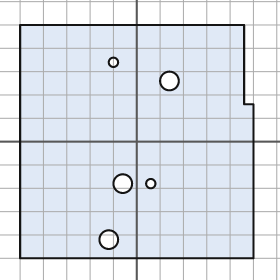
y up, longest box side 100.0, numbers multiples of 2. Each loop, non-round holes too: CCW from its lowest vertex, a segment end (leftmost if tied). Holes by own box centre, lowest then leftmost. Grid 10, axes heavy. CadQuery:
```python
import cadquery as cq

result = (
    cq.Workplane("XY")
    .moveTo(-50.0, -50.0)
    .lineTo(50.0, -50.0)
    .lineTo(50.0, 16.0)
    .lineTo(46.0, 16.0)
    .lineTo(46.0, 50.0)
    .lineTo(-50.0, 50.0)
    .close()
    .moveTo(-12.0, -42.0)
    .circle(4.0)
    .moveTo(-6.0, -18.0)
    .circle(4.0)
    .moveTo(6.0, -18.0)
    .circle(2.0)
    .moveTo(14.0, 26.0)
    .circle(4.0)
    .moveTo(-10.0, 34.0)
    .circle(2.0)
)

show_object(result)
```